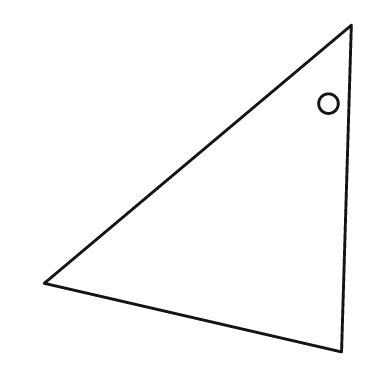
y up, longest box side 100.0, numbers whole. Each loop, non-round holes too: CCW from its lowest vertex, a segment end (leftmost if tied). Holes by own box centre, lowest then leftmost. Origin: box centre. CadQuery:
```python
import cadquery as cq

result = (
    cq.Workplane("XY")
    .moveTo(44.0, -50.0)
    .lineTo(47.0, 50.0)
    .lineTo(-47.0, -29.0)
    .close()
    .moveTo(40.0, 26.0)
    .circle(3.0)
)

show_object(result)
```